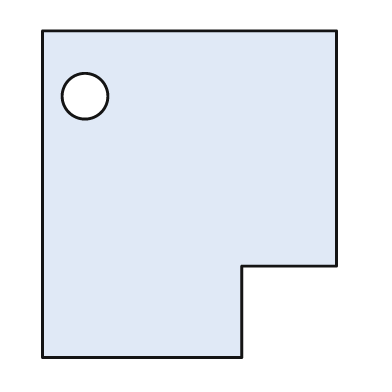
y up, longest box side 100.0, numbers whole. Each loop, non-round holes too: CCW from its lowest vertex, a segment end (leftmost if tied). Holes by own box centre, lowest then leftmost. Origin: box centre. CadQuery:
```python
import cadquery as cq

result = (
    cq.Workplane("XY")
    .moveTo(-45.0, -50.0)
    .lineTo(16.0, -50.0)
    .lineTo(16.0, -22.0)
    .lineTo(45.0, -22.0)
    .lineTo(45.0, 50.0)
    .lineTo(-45.0, 50.0)
    .close()
    .moveTo(-32.0, 30.0)
    .circle(7.0)
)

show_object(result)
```